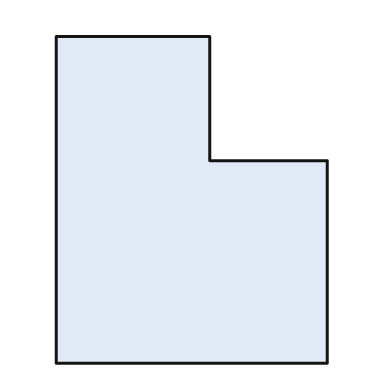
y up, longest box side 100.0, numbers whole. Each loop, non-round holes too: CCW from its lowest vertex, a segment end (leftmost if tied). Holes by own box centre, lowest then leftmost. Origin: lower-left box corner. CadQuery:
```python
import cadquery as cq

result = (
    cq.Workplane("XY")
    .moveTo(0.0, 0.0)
    .lineTo(83.0, 0.0)
    .lineTo(83.0, 62.0)
    .lineTo(47.0, 62.0)
    .lineTo(47.0, 100.0)
    .lineTo(0.0, 100.0)
    .close()
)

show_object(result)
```